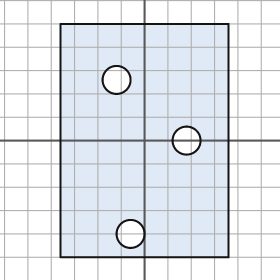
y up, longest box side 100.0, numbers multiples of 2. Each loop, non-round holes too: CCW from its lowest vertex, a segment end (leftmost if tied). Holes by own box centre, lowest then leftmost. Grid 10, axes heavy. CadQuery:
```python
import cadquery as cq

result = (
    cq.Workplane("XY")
    .moveTo(-36.0, -50.0)
    .lineTo(36.0, -50.0)
    .lineTo(36.0, 50.0)
    .lineTo(-36.0, 50.0)
    .close()
    .moveTo(-6.0, -40.0)
    .circle(6.0)
    .moveTo(18.0, 0.0)
    .circle(6.0)
    .moveTo(-12.0, 26.0)
    .circle(6.0)
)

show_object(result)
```